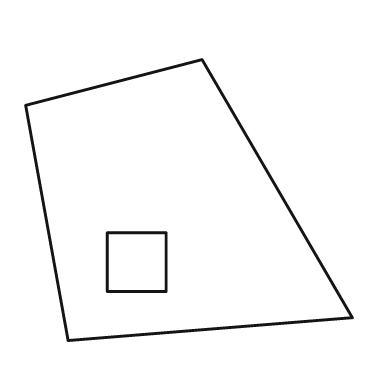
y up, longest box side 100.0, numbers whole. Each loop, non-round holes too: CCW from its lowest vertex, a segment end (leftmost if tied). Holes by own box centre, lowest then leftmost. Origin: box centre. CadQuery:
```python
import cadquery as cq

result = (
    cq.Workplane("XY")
    .moveTo(-37.0, -43.0)
    .lineTo(50.0, -36.0)
    .lineTo(4.0, 43.0)
    .lineTo(-50.0, 29.0)
    .close()
    .moveTo(-25.0, -28.0)
    .lineTo(-7.0, -28.0)
    .lineTo(-7.0, -10.0)
    .lineTo(-25.0, -10.0)
    .close()
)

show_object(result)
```